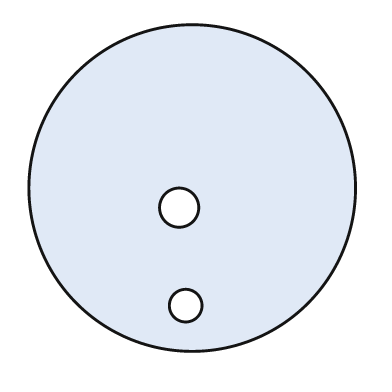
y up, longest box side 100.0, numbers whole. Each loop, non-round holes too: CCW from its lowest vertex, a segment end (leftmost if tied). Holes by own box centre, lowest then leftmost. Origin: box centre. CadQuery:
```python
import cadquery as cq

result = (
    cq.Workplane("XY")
    .moveTo(0.0, 0.0)
    .circle(50.0)
    .moveTo(-2.0, -36.0)
    .circle(5.0)
    .moveTo(-4.0, -6.0)
    .circle(6.0)
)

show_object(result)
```